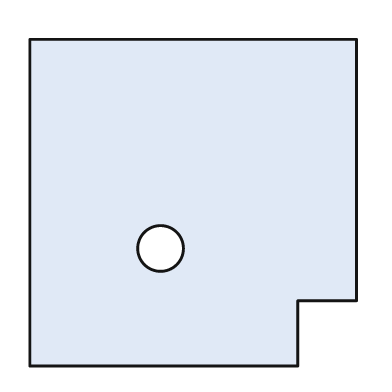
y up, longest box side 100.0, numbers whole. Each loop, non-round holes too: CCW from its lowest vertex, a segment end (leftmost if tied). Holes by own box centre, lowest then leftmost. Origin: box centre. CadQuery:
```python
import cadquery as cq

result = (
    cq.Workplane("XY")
    .moveTo(-50.0, -50.0)
    .lineTo(32.0, -50.0)
    .lineTo(32.0, -30.0)
    .lineTo(50.0, -30.0)
    .lineTo(50.0, 50.0)
    .lineTo(-50.0, 50.0)
    .close()
    .moveTo(-10.0, -14.0)
    .circle(7.0)
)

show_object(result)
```